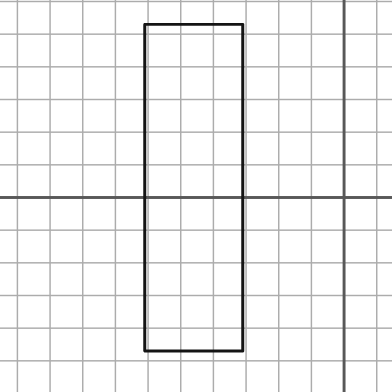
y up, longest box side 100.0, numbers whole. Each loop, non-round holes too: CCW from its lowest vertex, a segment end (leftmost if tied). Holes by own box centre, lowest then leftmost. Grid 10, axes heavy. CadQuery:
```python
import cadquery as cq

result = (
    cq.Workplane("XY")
    .moveTo(-61.0, -47.0)
    .lineTo(-31.0, -47.0)
    .lineTo(-31.0, 53.0)
    .lineTo(-61.0, 53.0)
    .close()
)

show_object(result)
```